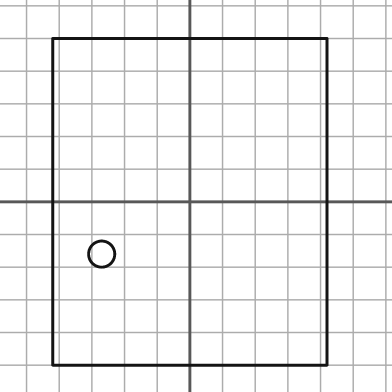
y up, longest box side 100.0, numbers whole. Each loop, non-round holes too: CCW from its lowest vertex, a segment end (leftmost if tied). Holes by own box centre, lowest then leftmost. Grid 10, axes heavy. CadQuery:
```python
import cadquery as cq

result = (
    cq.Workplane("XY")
    .moveTo(-42.0, -50.0)
    .lineTo(42.0, -50.0)
    .lineTo(42.0, 50.0)
    .lineTo(-42.0, 50.0)
    .close()
    .moveTo(-27.0, -16.0)
    .circle(4.0)
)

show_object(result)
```